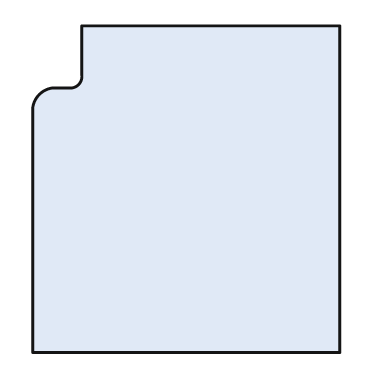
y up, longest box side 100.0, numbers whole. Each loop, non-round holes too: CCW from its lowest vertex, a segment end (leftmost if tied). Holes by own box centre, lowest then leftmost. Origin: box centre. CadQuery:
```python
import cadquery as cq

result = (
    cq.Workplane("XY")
    .moveTo(-47.0, -50.0)
    .lineTo(47.0, -50.0)
    .lineTo(47.0, 50.0)
    .lineTo(-32.0, 50.0)
    .lineTo(-32.0, 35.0)
    .threePointArc((-33.0, 32.0), (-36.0, 31.0))
    .lineTo(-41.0, 31.0)
    .threePointArc((-45.0, 29.0), (-47.0, 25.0))
    .close()
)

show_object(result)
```